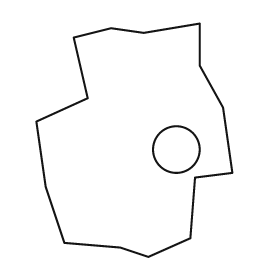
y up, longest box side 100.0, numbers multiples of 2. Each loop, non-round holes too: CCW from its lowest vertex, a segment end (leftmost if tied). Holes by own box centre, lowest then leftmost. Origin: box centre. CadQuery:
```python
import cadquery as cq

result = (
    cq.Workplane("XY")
    .moveTo(6.0, -50.0)
    .lineTo(24.0, -42.0)
    .lineTo(26.0, -16.0)
    .lineTo(42.0, -14.0)
    .lineTo(38.0, 14.0)
    .lineTo(28.0, 32.0)
    .lineTo(28.0, 50.0)
    .lineTo(4.0, 46.0)
    .lineTo(-10.0, 48.0)
    .lineTo(-26.0, 44.0)
    .lineTo(-20.0, 18.0)
    .lineTo(-42.0, 8.0)
    .lineTo(-38.0, -20.0)
    .lineTo(-30.0, -44.0)
    .lineTo(-6.0, -46.0)
    .close()
    .moveTo(18.0, -4.0)
    .circle(10.0)
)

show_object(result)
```